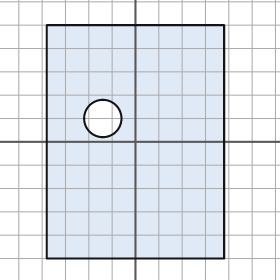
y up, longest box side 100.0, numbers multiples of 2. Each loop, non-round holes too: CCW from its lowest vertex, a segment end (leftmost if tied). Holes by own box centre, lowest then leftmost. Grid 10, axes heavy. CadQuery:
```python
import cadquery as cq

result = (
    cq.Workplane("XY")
    .moveTo(-38.0, -50.0)
    .lineTo(38.0, -50.0)
    .lineTo(38.0, 50.0)
    .lineTo(-38.0, 50.0)
    .close()
    .moveTo(-14.0, 10.0)
    .circle(8.0)
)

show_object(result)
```